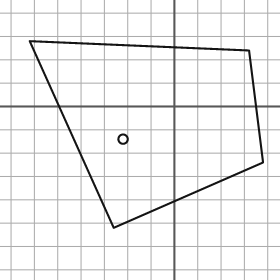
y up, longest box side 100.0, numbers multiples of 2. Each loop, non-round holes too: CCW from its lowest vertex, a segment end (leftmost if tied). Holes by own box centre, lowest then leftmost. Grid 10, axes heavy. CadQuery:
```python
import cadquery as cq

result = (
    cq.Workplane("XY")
    .moveTo(-26.0, -52.0)
    .lineTo(38.0, -24.0)
    .lineTo(32.0, 24.0)
    .lineTo(-62.0, 28.0)
    .close()
    .moveTo(-22.0, -14.0)
    .circle(2.0)
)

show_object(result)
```